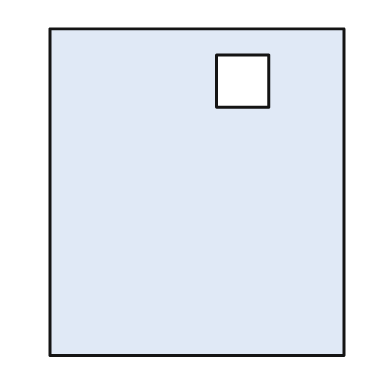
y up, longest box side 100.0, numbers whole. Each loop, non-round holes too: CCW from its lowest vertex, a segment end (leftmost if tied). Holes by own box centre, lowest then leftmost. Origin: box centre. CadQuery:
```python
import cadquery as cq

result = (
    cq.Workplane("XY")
    .moveTo(-45.0, -50.0)
    .lineTo(45.0, -50.0)
    .lineTo(45.0, 50.0)
    .lineTo(-45.0, 50.0)
    .close()
    .moveTo(6.0, 26.0)
    .lineTo(22.0, 26.0)
    .lineTo(22.0, 42.0)
    .lineTo(6.0, 42.0)
    .close()
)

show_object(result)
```